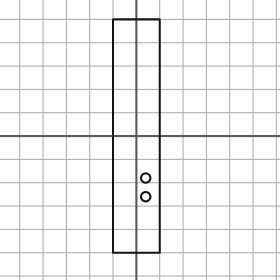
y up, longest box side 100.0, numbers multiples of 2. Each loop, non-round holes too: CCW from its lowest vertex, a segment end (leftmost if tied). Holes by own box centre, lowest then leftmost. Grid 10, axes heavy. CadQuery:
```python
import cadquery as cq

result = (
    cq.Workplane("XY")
    .moveTo(-10.0, -50.0)
    .lineTo(10.0, -50.0)
    .lineTo(10.0, 50.0)
    .lineTo(-10.0, 50.0)
    .close()
    .moveTo(4.0, -26.0)
    .circle(2.0)
    .moveTo(4.0, -18.0)
    .circle(2.0)
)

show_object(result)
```